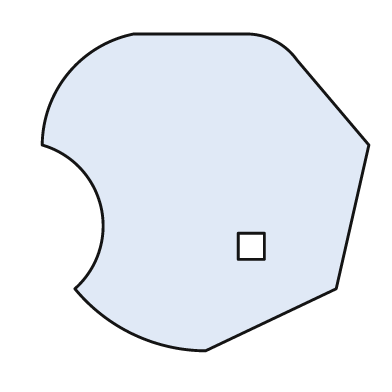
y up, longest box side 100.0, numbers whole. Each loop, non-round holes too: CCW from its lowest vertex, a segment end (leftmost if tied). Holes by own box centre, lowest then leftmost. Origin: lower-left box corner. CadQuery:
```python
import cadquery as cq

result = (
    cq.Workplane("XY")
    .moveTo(50.0, 0.0)
    .lineTo(90.0, 19.0)
    .lineTo(100.0, 63.0)
    .lineTo(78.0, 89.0)
    .threePointArc((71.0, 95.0), (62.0, 97.0))
    .lineTo(28.0, 97.0)
    .threePointArc((8.0, 85.0), (0.0, 63.0))
    .threePointArc((18.0, 44.0), (10.0, 19.0))
    .threePointArc((28.0, 5.0), (50.0, 0.0))
    .close()
    .moveTo(60.0, 28.0)
    .lineTo(68.0, 28.0)
    .lineTo(68.0, 36.0)
    .lineTo(60.0, 36.0)
    .close()
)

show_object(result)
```